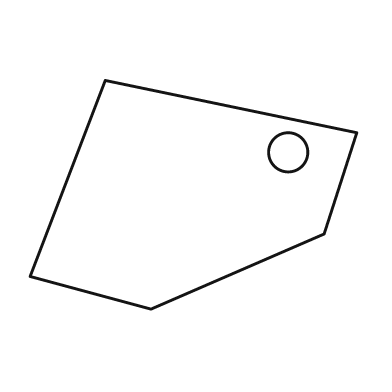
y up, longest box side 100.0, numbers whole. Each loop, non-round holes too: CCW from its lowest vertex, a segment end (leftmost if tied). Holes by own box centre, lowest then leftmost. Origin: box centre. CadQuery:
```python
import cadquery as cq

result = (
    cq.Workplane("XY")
    .moveTo(-13.0, -35.0)
    .lineTo(40.0, -12.0)
    .lineTo(50.0, 19.0)
    .lineTo(-27.0, 35.0)
    .lineTo(-50.0, -25.0)
    .close()
    .moveTo(29.0, 13.0)
    .circle(6.0)
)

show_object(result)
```